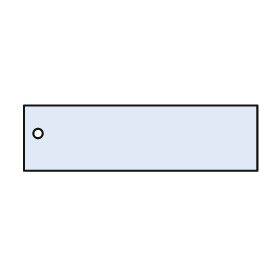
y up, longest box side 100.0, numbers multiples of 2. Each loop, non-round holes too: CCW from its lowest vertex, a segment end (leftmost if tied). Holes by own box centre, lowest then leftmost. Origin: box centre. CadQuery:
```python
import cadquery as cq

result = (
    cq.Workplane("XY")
    .moveTo(-50.0, -14.0)
    .lineTo(50.0, -14.0)
    .lineTo(50.0, 14.0)
    .lineTo(-50.0, 14.0)
    .close()
    .moveTo(-44.0, 2.0)
    .circle(2.0)
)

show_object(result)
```